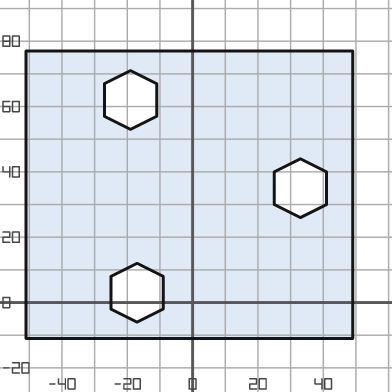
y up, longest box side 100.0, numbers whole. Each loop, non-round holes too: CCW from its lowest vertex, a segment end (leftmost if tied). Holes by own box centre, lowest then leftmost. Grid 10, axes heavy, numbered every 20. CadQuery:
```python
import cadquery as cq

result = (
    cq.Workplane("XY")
    .moveTo(-51.0, -11.0)
    .lineTo(49.0, -11.0)
    .lineTo(49.0, 77.0)
    .lineTo(-51.0, 77.0)
    .close()
    .moveTo(-17.0, -6.0)
    .lineTo(-9.0, -2.0)
    .lineTo(-9.0, 8.0)
    .lineTo(-17.0, 12.0)
    .lineTo(-25.0, 8.0)
    .lineTo(-25.0, -2.0)
    .close()
    .moveTo(33.0, 26.0)
    .lineTo(41.0, 30.0)
    .lineTo(41.0, 40.0)
    .lineTo(33.0, 44.0)
    .lineTo(25.0, 40.0)
    .lineTo(25.0, 30.0)
    .close()
    .moveTo(-19.0, 53.0)
    .lineTo(-11.0, 57.0)
    .lineTo(-11.0, 67.0)
    .lineTo(-19.0, 71.0)
    .lineTo(-27.0, 67.0)
    .lineTo(-27.0, 57.0)
    .close()
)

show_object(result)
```